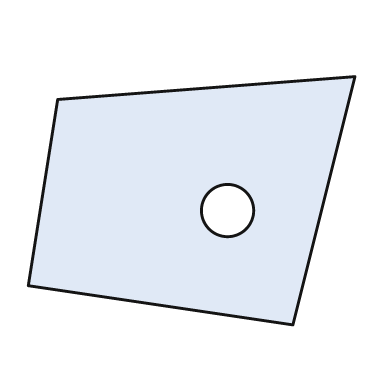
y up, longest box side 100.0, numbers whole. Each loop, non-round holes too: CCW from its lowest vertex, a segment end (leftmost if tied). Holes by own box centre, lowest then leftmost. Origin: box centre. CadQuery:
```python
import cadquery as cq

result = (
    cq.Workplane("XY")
    .moveTo(31.0, -38.0)
    .lineTo(50.0, 38.0)
    .lineTo(-41.0, 31.0)
    .lineTo(-50.0, -26.0)
    .close()
    .moveTo(11.0, -3.0)
    .circle(8.0)
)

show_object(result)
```